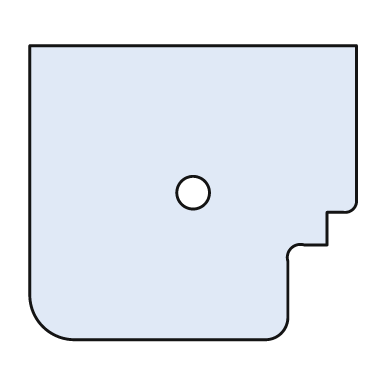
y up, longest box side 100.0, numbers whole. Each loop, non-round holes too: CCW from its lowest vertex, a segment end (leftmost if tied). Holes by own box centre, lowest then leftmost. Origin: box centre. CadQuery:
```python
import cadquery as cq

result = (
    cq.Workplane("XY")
    .moveTo(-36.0, -45.0)
    .lineTo(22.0, -45.0)
    .threePointArc((27.0, -43.0), (29.0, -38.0))
    .lineTo(29.0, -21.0)
    .threePointArc((30.0, -17.0), (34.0, -16.0))
    .lineTo(41.0, -16.0)
    .lineTo(41.0, -6.0)
    .lineTo(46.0, -6.0)
    .threePointArc((49.0, -5.0), (50.0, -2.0))
    .lineTo(50.0, 45.0)
    .lineTo(-50.0, 45.0)
    .lineTo(-50.0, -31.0)
    .threePointArc((-46.0, -41.0), (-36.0, -45.0))
    .close()
    .moveTo(0.0, 0.0)
    .circle(5.0)
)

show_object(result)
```